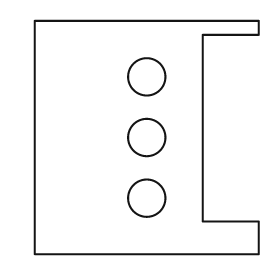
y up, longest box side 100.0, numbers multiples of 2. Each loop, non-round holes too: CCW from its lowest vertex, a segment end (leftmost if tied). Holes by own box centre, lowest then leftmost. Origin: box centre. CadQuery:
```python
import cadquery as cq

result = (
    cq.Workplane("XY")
    .moveTo(-48.0, -50.0)
    .lineTo(48.0, -50.0)
    .lineTo(48.0, -36.0)
    .lineTo(24.0, -36.0)
    .lineTo(24.0, 44.0)
    .lineTo(48.0, 44.0)
    .lineTo(48.0, 50.0)
    .lineTo(-48.0, 50.0)
    .close()
    .moveTo(0.0, -26.0)
    .circle(8.0)
    .moveTo(0.0, 0.0)
    .circle(8.0)
    .moveTo(0.0, 26.0)
    .circle(8.0)
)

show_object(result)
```